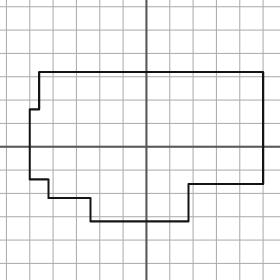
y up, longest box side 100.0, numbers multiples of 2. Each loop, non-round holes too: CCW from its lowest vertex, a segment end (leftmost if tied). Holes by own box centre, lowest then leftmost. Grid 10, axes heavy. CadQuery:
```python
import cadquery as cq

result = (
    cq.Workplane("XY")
    .moveTo(-24.0, -32.0)
    .lineTo(18.0, -32.0)
    .lineTo(18.0, -16.0)
    .lineTo(50.0, -16.0)
    .lineTo(50.0, 32.0)
    .lineTo(-46.0, 32.0)
    .lineTo(-46.0, 16.0)
    .lineTo(-50.0, 16.0)
    .lineTo(-50.0, -14.0)
    .lineTo(-42.0, -14.0)
    .lineTo(-42.0, -22.0)
    .lineTo(-24.0, -22.0)
    .close()
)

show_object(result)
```